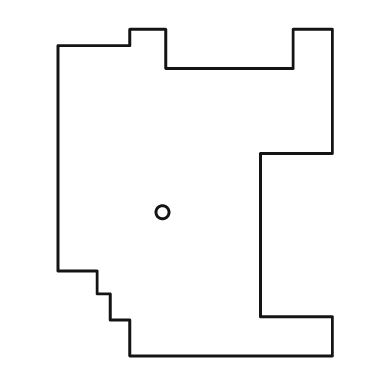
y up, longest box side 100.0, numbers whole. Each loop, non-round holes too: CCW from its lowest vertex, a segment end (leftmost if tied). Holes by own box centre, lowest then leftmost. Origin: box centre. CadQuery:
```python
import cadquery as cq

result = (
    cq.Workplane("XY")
    .moveTo(-20.0, -50.0)
    .lineTo(42.0, -50.0)
    .lineTo(42.0, -38.0)
    .lineTo(20.0, -38.0)
    .lineTo(20.0, 12.0)
    .lineTo(42.0, 12.0)
    .lineTo(42.0, 50.0)
    .lineTo(30.0, 50.0)
    .lineTo(30.0, 38.0)
    .lineTo(-9.0, 38.0)
    .lineTo(-9.0, 50.0)
    .lineTo(-20.0, 50.0)
    .lineTo(-20.0, 45.0)
    .lineTo(-42.0, 45.0)
    .lineTo(-42.0, -24.0)
    .lineTo(-30.0, -24.0)
    .lineTo(-30.0, -31.0)
    .lineTo(-26.0, -31.0)
    .lineTo(-26.0, -39.0)
    .lineTo(-20.0, -39.0)
    .close()
    .moveTo(-10.0, -6.0)
    .circle(2.0)
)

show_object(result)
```